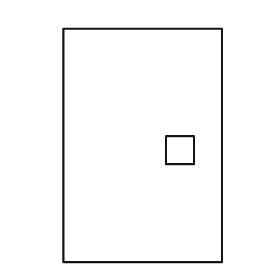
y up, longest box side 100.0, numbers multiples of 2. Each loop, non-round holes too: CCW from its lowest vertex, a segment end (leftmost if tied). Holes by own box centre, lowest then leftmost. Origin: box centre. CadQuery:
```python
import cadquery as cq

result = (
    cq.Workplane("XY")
    .moveTo(-34.0, -50.0)
    .lineTo(34.0, -50.0)
    .lineTo(34.0, 50.0)
    .lineTo(-34.0, 50.0)
    .close()
    .moveTo(10.0, -8.0)
    .lineTo(22.0, -8.0)
    .lineTo(22.0, 4.0)
    .lineTo(10.0, 4.0)
    .close()
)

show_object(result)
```